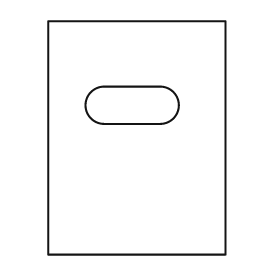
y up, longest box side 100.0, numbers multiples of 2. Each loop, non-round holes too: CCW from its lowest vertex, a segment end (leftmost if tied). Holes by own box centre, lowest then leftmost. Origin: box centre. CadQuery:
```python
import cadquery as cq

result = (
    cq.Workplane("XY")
    .moveTo(-38.0, -50.0)
    .lineTo(38.0, -50.0)
    .lineTo(38.0, 50.0)
    .lineTo(-38.0, 50.0)
    .close()
    .moveTo(-14.0, 6.0)
    .lineTo(10.0, 6.0)
    .threePointArc((18.0, 14.0), (10.0, 22.0))
    .lineTo(-14.0, 22.0)
    .threePointArc((-22.0, 14.0), (-14.0, 6.0))
    .close()
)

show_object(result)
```